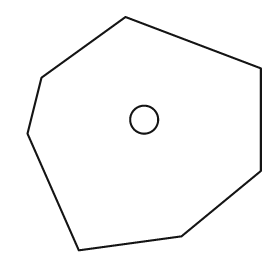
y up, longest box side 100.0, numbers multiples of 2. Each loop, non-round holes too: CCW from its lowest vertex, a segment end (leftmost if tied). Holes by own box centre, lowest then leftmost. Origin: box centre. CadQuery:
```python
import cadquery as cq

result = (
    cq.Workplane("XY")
    .moveTo(-28.0, -50.0)
    .lineTo(16.0, -44.0)
    .lineTo(50.0, -16.0)
    .lineTo(50.0, 28.0)
    .lineTo(-8.0, 50.0)
    .lineTo(-44.0, 24.0)
    .lineTo(-50.0, 0.0)
    .close()
    .moveTo(0.0, 6.0)
    .circle(6.0)
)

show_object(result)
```